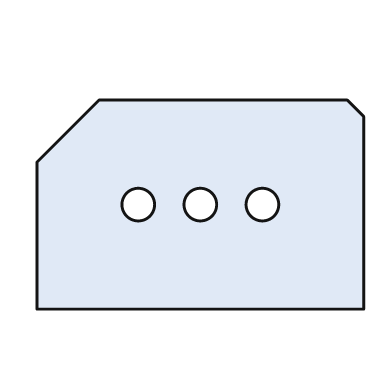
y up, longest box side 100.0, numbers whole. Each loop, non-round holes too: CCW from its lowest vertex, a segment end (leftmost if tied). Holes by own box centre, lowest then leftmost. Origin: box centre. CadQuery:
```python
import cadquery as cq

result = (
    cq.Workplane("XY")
    .moveTo(-50.0, -32.0)
    .lineTo(50.0, -32.0)
    .lineTo(50.0, 27.0)
    .lineTo(45.0, 32.0)
    .lineTo(-31.0, 32.0)
    .lineTo(-50.0, 13.0)
    .close()
    .moveTo(-19.0, 0.0)
    .circle(5.0)
    .moveTo(0.0, 0.0)
    .circle(5.0)
    .moveTo(19.0, 0.0)
    .circle(5.0)
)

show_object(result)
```